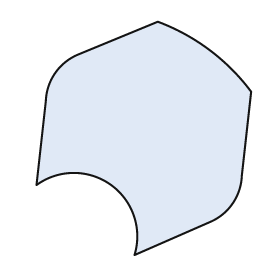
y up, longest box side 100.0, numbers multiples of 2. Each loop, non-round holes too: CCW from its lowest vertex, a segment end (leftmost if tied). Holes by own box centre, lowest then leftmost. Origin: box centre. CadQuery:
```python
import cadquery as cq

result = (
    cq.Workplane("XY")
    .moveTo(-4.0, -50.0)
    .lineTo(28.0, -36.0)
    .threePointArc((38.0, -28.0), (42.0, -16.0))
    .lineTo(46.0, 20.0)
    .threePointArc((28.0, 38.0), (6.0, 50.0))
    .lineTo(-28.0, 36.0)
    .threePointArc((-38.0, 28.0), (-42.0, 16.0))
    .lineTo(-46.0, -20.0)
    .threePointArc((-14.0, -20.0), (-4.0, -50.0))
    .close()
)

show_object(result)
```